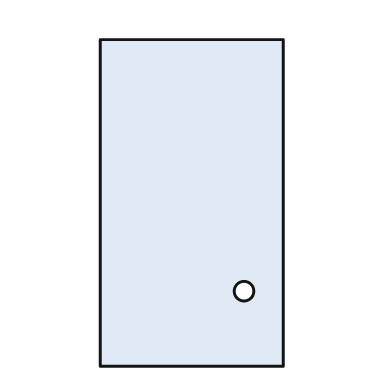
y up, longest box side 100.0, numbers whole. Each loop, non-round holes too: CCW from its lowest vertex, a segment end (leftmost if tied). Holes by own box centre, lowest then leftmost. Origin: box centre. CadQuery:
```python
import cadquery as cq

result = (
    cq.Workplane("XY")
    .moveTo(-28.0, -50.0)
    .lineTo(28.0, -50.0)
    .lineTo(28.0, 50.0)
    .lineTo(-28.0, 50.0)
    .close()
    .moveTo(16.0, -27.0)
    .circle(3.0)
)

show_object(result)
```